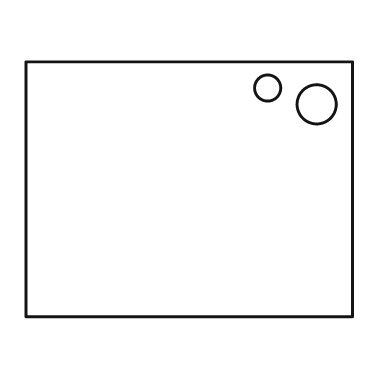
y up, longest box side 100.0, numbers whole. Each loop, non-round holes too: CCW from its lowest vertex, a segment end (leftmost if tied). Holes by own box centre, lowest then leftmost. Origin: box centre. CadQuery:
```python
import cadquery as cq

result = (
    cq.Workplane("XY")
    .moveTo(-50.0, -39.0)
    .lineTo(50.0, -39.0)
    .lineTo(50.0, 39.0)
    .lineTo(-50.0, 39.0)
    .close()
    .moveTo(39.0, 26.0)
    .circle(6.0)
    .moveTo(24.0, 31.0)
    .circle(4.0)
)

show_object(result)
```